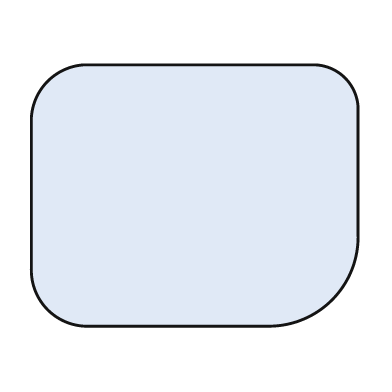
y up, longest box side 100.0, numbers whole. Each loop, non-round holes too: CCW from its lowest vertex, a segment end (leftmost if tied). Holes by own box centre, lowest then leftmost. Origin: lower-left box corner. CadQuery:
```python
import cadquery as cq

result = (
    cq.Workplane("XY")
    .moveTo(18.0, 0.0)
    .lineTo(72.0, 0.0)
    .threePointArc((92.0, 8.0), (100.0, 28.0))
    .lineTo(100.0, 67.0)
    .threePointArc((96.0, 76.0), (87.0, 80.0))
    .lineTo(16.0, 80.0)
    .threePointArc((5.0, 75.0), (0.0, 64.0))
    .lineTo(0.0, 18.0)
    .threePointArc((5.0, 5.0), (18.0, 0.0))
    .close()
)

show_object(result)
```